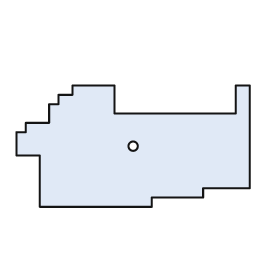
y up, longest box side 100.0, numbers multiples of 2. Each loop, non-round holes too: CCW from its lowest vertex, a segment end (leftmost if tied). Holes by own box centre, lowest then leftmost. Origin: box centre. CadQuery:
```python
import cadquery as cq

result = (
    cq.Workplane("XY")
    .moveTo(-40.0, -26.0)
    .lineTo(8.0, -26.0)
    .lineTo(8.0, -22.0)
    .lineTo(30.0, -22.0)
    .lineTo(30.0, -18.0)
    .lineTo(50.0, -18.0)
    .lineTo(50.0, 26.0)
    .lineTo(44.0, 26.0)
    .lineTo(44.0, 14.0)
    .lineTo(-8.0, 14.0)
    .lineTo(-8.0, 26.0)
    .lineTo(-26.0, 26.0)
    .lineTo(-26.0, 22.0)
    .lineTo(-32.0, 22.0)
    .lineTo(-32.0, 18.0)
    .lineTo(-36.0, 18.0)
    .lineTo(-36.0, 10.0)
    .lineTo(-46.0, 10.0)
    .lineTo(-46.0, 6.0)
    .lineTo(-50.0, 6.0)
    .lineTo(-50.0, -4.0)
    .lineTo(-40.0, -4.0)
    .close()
    .moveTo(0.0, 0.0)
    .circle(2.0)
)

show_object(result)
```